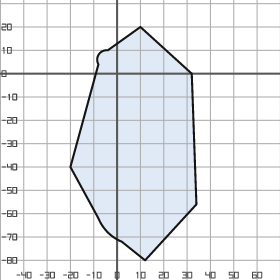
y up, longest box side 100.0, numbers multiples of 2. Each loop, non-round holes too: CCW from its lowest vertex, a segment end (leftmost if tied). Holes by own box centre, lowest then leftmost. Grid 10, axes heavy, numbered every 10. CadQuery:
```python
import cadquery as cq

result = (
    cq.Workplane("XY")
    .moveTo(12.0, -80.0)
    .lineTo(34.0, -56.0)
    .lineTo(32.0, 0.0)
    .lineTo(10.0, 20.0)
    .lineTo(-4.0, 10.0)
    .threePointArc((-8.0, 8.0), (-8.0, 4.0))
    .lineTo(-20.0, -40.0)
    .lineTo(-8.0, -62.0)
    .threePointArc((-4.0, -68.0), (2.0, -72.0))
    .close()
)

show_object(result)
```